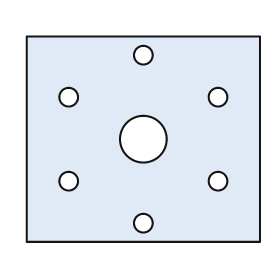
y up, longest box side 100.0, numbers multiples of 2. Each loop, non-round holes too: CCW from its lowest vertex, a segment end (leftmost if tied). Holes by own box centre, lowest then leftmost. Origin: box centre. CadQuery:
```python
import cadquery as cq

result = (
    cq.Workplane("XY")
    .moveTo(-50.0, -44.0)
    .lineTo(50.0, -44.0)
    .lineTo(50.0, 44.0)
    .lineTo(-50.0, 44.0)
    .close()
    .moveTo(0.0, -36.0)
    .circle(4.0)
    .moveTo(-32.0, -18.0)
    .circle(4.0)
    .moveTo(32.0, -18.0)
    .circle(4.0)
    .moveTo(0.0, 0.0)
    .circle(10.0)
    .moveTo(-32.0, 18.0)
    .circle(4.0)
    .moveTo(32.0, 18.0)
    .circle(4.0)
    .moveTo(0.0, 36.0)
    .circle(4.0)
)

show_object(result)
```